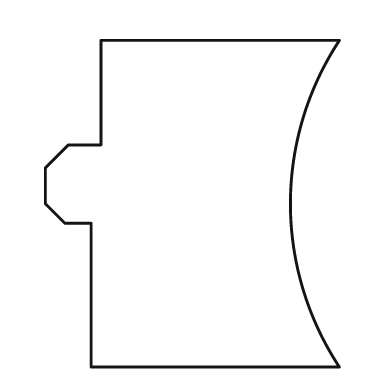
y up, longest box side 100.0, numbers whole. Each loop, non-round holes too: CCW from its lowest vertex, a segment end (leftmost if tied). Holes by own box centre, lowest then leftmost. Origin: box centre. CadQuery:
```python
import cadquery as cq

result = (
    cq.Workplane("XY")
    .moveTo(-31.0, -50.0)
    .lineTo(45.0, -50.0)
    .threePointArc((30.0, 0.0), (45.0, 50.0))
    .lineTo(-28.0, 50.0)
    .lineTo(-28.0, 18.0)
    .lineTo(-38.0, 18.0)
    .lineTo(-45.0, 11.0)
    .lineTo(-45.0, 0.0)
    .lineTo(-39.0, -6.0)
    .lineTo(-31.0, -6.0)
    .close()
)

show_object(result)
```